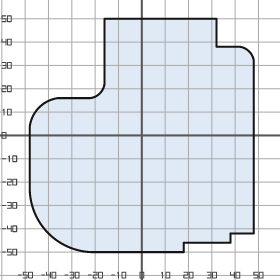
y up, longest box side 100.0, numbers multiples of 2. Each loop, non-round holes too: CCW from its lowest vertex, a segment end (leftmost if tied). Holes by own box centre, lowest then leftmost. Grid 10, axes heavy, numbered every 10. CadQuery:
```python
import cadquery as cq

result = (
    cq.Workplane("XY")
    .moveTo(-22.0, -50.0)
    .lineTo(18.0, -50.0)
    .lineTo(18.0, -46.0)
    .lineTo(38.0, -46.0)
    .lineTo(38.0, -42.0)
    .lineTo(48.0, -42.0)
    .lineTo(48.0, 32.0)
    .threePointArc((46.0, 36.0), (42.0, 38.0))
    .lineTo(32.0, 38.0)
    .lineTo(32.0, 50.0)
    .lineTo(-16.0, 50.0)
    .lineTo(-16.0, 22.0)
    .threePointArc((-18.0, 18.0), (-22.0, 16.0))
    .lineTo(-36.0, 16.0)
    .threePointArc((-44.0, 12.0), (-48.0, 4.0))
    .lineTo(-48.0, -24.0)
    .threePointArc((-40.0, -42.0), (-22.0, -50.0))
    .close()
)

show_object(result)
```